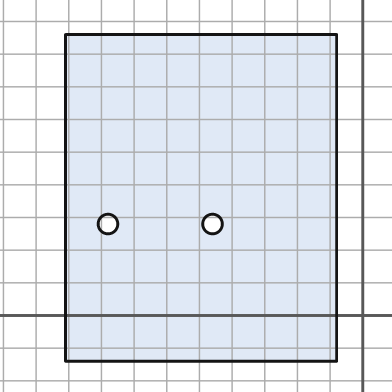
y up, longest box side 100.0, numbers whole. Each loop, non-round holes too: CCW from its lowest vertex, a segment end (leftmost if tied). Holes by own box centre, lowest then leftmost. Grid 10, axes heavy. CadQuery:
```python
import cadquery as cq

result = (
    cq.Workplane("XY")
    .moveTo(-91.0, -14.0)
    .lineTo(-8.0, -14.0)
    .lineTo(-8.0, 86.0)
    .lineTo(-91.0, 86.0)
    .close()
    .moveTo(-78.0, 28.0)
    .circle(3.0)
    .moveTo(-46.0, 28.0)
    .circle(3.0)
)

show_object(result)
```